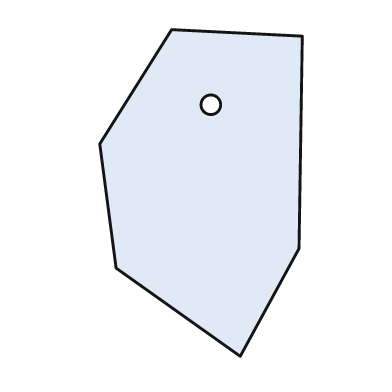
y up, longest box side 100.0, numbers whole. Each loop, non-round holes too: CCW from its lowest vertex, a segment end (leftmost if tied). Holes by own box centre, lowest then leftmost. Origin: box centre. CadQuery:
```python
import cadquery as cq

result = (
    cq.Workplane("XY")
    .moveTo(12.0, -50.0)
    .lineTo(30.0, -17.0)
    .lineTo(31.0, 48.0)
    .lineTo(-9.0, 50.0)
    .lineTo(-31.0, 15.0)
    .lineTo(-26.0, -23.0)
    .close()
    .moveTo(3.0, 27.0)
    .circle(3.0)
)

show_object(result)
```